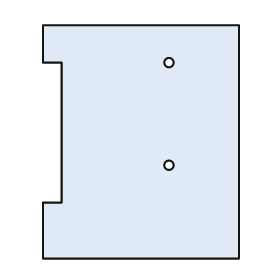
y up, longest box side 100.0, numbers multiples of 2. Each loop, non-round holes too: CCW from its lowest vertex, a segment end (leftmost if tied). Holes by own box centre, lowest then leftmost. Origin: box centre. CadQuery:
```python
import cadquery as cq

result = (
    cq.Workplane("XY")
    .moveTo(-42.0, -50.0)
    .lineTo(42.0, -50.0)
    .lineTo(42.0, 50.0)
    .lineTo(-42.0, 50.0)
    .lineTo(-42.0, 34.0)
    .lineTo(-34.0, 34.0)
    .lineTo(-34.0, -26.0)
    .lineTo(-42.0, -26.0)
    .close()
    .moveTo(12.0, -10.0)
    .circle(2.0)
    .moveTo(12.0, 34.0)
    .circle(2.0)
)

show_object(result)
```